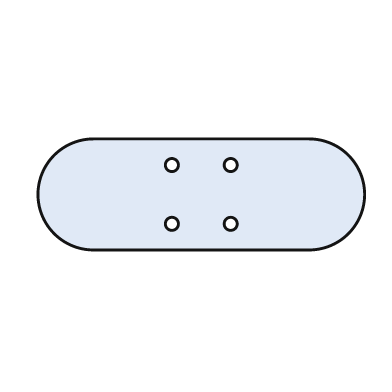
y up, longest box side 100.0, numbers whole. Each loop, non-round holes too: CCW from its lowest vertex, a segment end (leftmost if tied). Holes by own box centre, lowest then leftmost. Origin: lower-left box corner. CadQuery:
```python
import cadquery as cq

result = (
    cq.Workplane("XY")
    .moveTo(17.0, 0.0)
    .lineTo(83.0, 0.0)
    .threePointArc((100.0, 17.0), (83.0, 34.0))
    .lineTo(17.0, 34.0)
    .threePointArc((0.0, 17.0), (17.0, 0.0))
    .close()
    .moveTo(41.0, 8.0)
    .circle(2.0)
    .moveTo(59.0, 8.0)
    .circle(2.0)
    .moveTo(41.0, 26.0)
    .circle(2.0)
    .moveTo(59.0, 26.0)
    .circle(2.0)
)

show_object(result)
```